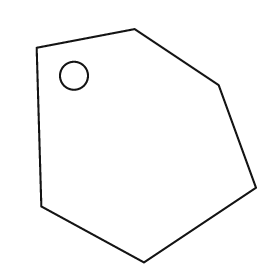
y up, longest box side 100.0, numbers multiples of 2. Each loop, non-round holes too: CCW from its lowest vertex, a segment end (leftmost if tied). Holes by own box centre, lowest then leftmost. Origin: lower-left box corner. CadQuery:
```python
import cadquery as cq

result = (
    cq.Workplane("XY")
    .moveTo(46.0, 0.0)
    .lineTo(94.0, 32.0)
    .lineTo(78.0, 76.0)
    .lineTo(42.0, 100.0)
    .lineTo(0.0, 92.0)
    .lineTo(2.0, 24.0)
    .close()
    .moveTo(16.0, 80.0)
    .circle(6.0)
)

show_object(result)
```